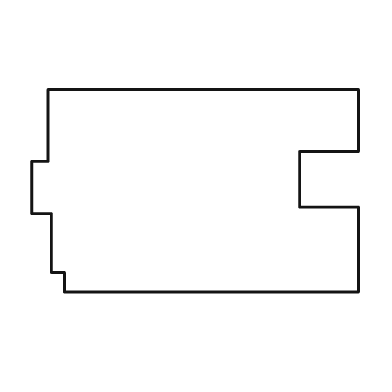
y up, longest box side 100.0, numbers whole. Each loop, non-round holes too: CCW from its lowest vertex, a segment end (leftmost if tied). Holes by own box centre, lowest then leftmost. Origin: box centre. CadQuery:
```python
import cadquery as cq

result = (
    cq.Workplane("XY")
    .moveTo(-40.0, -31.0)
    .lineTo(50.0, -31.0)
    .lineTo(50.0, -5.0)
    .lineTo(32.0, -5.0)
    .lineTo(32.0, 12.0)
    .lineTo(50.0, 12.0)
    .lineTo(50.0, 31.0)
    .lineTo(-45.0, 31.0)
    .lineTo(-45.0, 9.0)
    .lineTo(-50.0, 9.0)
    .lineTo(-50.0, -7.0)
    .lineTo(-44.0, -7.0)
    .lineTo(-44.0, -25.0)
    .lineTo(-40.0, -25.0)
    .close()
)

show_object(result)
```